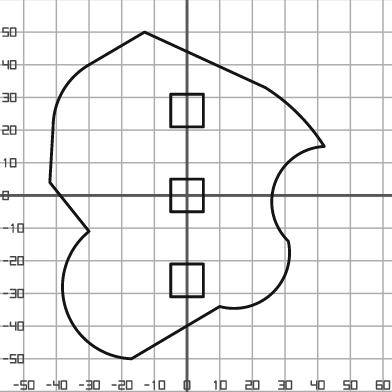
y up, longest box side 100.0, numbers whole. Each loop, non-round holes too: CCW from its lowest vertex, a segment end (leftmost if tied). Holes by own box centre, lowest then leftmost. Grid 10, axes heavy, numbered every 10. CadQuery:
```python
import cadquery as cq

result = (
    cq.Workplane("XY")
    .moveTo(-17.0, -50.0)
    .lineTo(10.0, -34.0)
    .threePointArc((26.0, -30.0), (31.0, -14.0))
    .threePointArc((27.0, 4.0), (42.0, 15.0))
    .threePointArc((34.0, 25.0), (24.0, 33.0))
    .lineTo(-13.0, 50.0)
    .lineTo(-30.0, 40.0)
    .threePointArc((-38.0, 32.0), (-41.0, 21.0))
    .lineTo(-42.0, 4.0)
    .lineTo(-30.0, -11.0)
    .threePointArc((-37.0, -35.0), (-17.0, -50.0))
    .close()
    .moveTo(-5.0, -31.0)
    .lineTo(5.0, -31.0)
    .lineTo(5.0, -21.0)
    .lineTo(-5.0, -21.0)
    .close()
    .moveTo(-5.0, -5.0)
    .lineTo(5.0, -5.0)
    .lineTo(5.0, 5.0)
    .lineTo(-5.0, 5.0)
    .close()
    .moveTo(-5.0, 21.0)
    .lineTo(5.0, 21.0)
    .lineTo(5.0, 31.0)
    .lineTo(-5.0, 31.0)
    .close()
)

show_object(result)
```